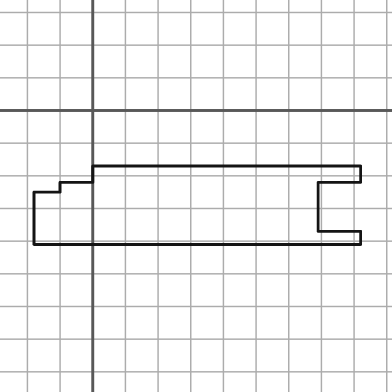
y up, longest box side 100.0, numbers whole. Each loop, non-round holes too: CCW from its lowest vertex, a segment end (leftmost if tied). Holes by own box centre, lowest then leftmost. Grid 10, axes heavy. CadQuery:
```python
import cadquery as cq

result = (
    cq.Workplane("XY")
    .moveTo(-18.0, -41.0)
    .lineTo(82.0, -41.0)
    .lineTo(82.0, -37.0)
    .lineTo(69.0, -37.0)
    .lineTo(69.0, -22.0)
    .lineTo(82.0, -22.0)
    .lineTo(82.0, -17.0)
    .lineTo(0.0, -17.0)
    .lineTo(0.0, -22.0)
    .lineTo(-10.0, -22.0)
    .lineTo(-10.0, -25.0)
    .lineTo(-18.0, -25.0)
    .close()
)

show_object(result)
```